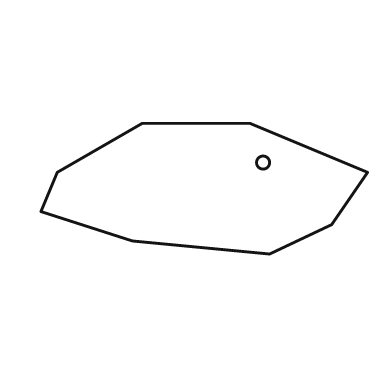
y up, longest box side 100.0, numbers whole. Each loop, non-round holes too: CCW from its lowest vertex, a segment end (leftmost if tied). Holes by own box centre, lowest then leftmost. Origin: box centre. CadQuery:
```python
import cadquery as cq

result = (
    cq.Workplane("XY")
    .moveTo(20.0, -20.0)
    .lineTo(39.0, -11.0)
    .lineTo(50.0, 5.0)
    .lineTo(14.0, 20.0)
    .lineTo(-19.0, 20.0)
    .lineTo(-45.0, 5.0)
    .lineTo(-50.0, -7.0)
    .lineTo(-22.0, -16.0)
    .close()
    .moveTo(18.0, 8.0)
    .circle(2.0)
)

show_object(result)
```